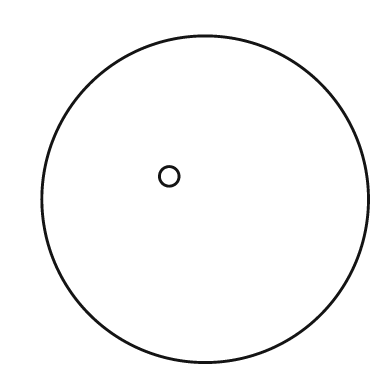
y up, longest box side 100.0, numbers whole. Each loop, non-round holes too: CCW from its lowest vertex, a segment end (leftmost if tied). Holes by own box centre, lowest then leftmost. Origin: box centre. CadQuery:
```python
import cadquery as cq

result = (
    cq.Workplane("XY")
    .moveTo(0.0, 0.0)
    .circle(50.0)
    .moveTo(-11.0, 7.0)
    .circle(3.0)
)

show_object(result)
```